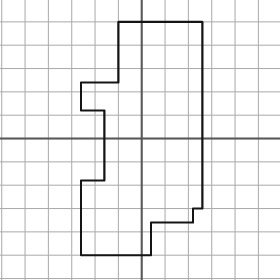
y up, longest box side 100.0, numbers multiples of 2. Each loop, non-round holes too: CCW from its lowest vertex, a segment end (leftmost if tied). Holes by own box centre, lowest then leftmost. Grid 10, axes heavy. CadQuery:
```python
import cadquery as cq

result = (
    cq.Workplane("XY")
    .moveTo(-26.0, -50.0)
    .lineTo(4.0, -50.0)
    .lineTo(4.0, -36.0)
    .lineTo(22.0, -36.0)
    .lineTo(22.0, -30.0)
    .lineTo(26.0, -30.0)
    .lineTo(26.0, 50.0)
    .lineTo(-10.0, 50.0)
    .lineTo(-10.0, 24.0)
    .lineTo(-26.0, 24.0)
    .lineTo(-26.0, 12.0)
    .lineTo(-16.0, 12.0)
    .lineTo(-16.0, -18.0)
    .lineTo(-26.0, -18.0)
    .close()
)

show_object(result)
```